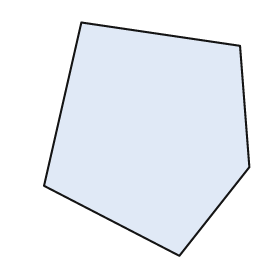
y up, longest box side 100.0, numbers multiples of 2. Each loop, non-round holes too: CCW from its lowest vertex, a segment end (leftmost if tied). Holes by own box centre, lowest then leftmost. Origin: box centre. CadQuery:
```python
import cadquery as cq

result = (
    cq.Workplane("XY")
    .moveTo(14.0, -50.0)
    .lineTo(44.0, -12.0)
    .lineTo(40.0, 40.0)
    .lineTo(-28.0, 50.0)
    .lineTo(-44.0, -20.0)
    .close()
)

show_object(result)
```